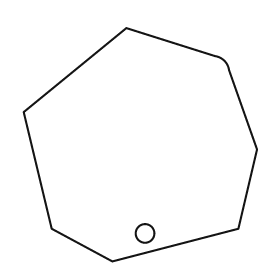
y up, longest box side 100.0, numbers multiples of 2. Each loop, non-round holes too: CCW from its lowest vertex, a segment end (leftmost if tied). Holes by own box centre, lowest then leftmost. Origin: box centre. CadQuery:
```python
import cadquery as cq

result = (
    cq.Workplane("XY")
    .moveTo(-12.0, -50.0)
    .lineTo(42.0, -36.0)
    .lineTo(50.0, -2.0)
    .lineTo(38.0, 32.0)
    .threePointArc((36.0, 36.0), (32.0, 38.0))
    .lineTo(-6.0, 50.0)
    .lineTo(-50.0, 14.0)
    .lineTo(-38.0, -36.0)
    .close()
    .moveTo(2.0, -38.0)
    .circle(4.0)
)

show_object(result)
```